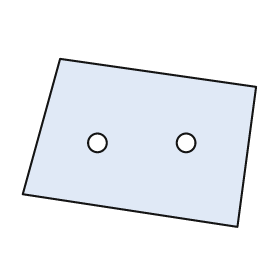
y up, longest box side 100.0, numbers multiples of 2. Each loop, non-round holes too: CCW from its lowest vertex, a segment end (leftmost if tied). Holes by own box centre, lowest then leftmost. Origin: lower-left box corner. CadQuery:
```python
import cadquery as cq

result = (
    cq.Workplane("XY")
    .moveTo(92.0, 0.0)
    .lineTo(100.0, 60.0)
    .lineTo(16.0, 72.0)
    .lineTo(0.0, 14.0)
    .close()
    .moveTo(32.0, 36.0)
    .circle(4.0)
    .moveTo(70.0, 36.0)
    .circle(4.0)
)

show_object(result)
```